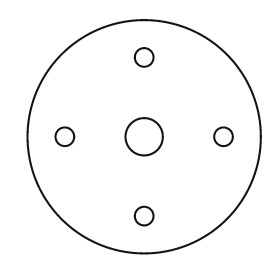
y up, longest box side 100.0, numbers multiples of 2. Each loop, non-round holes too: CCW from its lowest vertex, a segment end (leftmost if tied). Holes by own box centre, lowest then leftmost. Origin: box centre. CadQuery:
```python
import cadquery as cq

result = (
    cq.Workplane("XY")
    .moveTo(0.0, 0.0)
    .circle(50.0)
    .moveTo(0.0, -34.0)
    .circle(4.0)
    .moveTo(-34.0, 0.0)
    .circle(4.0)
    .moveTo(0.0, 0.0)
    .circle(8.0)
    .moveTo(34.0, 0.0)
    .circle(4.0)
    .moveTo(0.0, 34.0)
    .circle(4.0)
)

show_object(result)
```